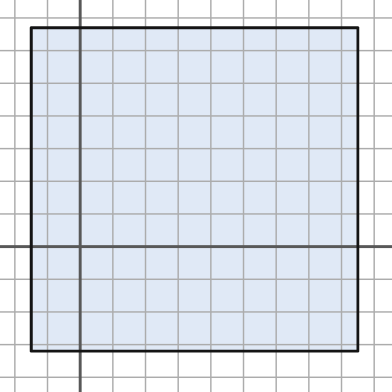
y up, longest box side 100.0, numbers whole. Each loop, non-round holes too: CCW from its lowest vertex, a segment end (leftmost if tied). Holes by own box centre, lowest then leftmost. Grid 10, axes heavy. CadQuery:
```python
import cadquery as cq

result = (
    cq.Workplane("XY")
    .moveTo(-15.0, -32.0)
    .lineTo(85.0, -32.0)
    .lineTo(85.0, 67.0)
    .lineTo(-15.0, 67.0)
    .close()
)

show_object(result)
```